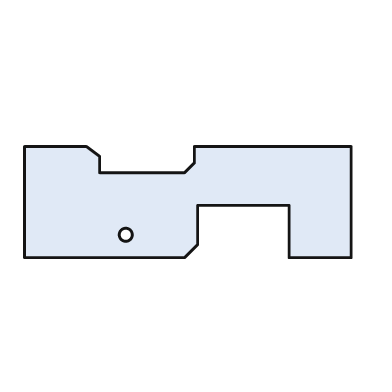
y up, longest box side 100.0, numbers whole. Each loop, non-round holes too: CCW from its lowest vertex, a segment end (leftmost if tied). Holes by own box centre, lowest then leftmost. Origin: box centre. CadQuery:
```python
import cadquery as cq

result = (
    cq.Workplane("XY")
    .moveTo(-50.0, -17.0)
    .lineTo(-1.0, -17.0)
    .lineTo(3.0, -13.0)
    .lineTo(3.0, -1.0)
    .lineTo(31.0, -1.0)
    .lineTo(31.0, -17.0)
    .lineTo(50.0, -17.0)
    .lineTo(50.0, 17.0)
    .lineTo(2.0, 17.0)
    .lineTo(2.0, 12.0)
    .lineTo(-1.0, 9.0)
    .lineTo(-27.0, 9.0)
    .lineTo(-27.0, 14.0)
    .lineTo(-31.0, 17.0)
    .lineTo(-50.0, 17.0)
    .close()
    .moveTo(-19.0, -10.0)
    .circle(2.0)
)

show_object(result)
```